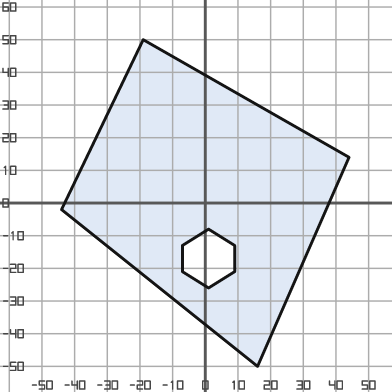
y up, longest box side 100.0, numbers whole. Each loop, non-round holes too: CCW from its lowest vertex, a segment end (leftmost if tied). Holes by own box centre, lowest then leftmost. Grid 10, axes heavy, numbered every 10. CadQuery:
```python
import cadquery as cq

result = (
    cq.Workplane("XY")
    .moveTo(16.0, -50.0)
    .lineTo(44.0, 14.0)
    .lineTo(-19.0, 50.0)
    .lineTo(-44.0, -2.0)
    .close()
    .moveTo(1.0, -26.0)
    .lineTo(9.0, -21.0)
    .lineTo(9.0, -13.0)
    .lineTo(1.0, -8.0)
    .lineTo(-7.0, -13.0)
    .lineTo(-7.0, -21.0)
    .close()
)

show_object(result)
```